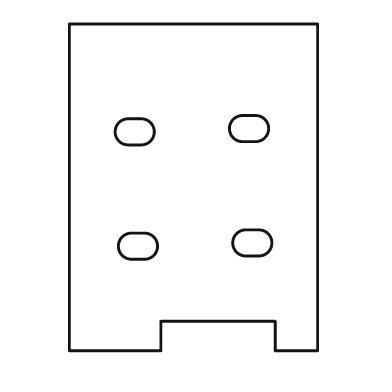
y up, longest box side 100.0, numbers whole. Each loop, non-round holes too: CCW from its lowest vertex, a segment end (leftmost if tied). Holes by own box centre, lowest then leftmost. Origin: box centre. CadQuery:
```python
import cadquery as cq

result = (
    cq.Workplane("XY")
    .moveTo(-38.0, -50.0)
    .lineTo(-10.0, -50.0)
    .lineTo(-10.0, -41.0)
    .lineTo(25.0, -41.0)
    .lineTo(25.0, -50.0)
    .lineTo(38.0, -50.0)
    .lineTo(38.0, 50.0)
    .lineTo(-38.0, 50.0)
    .close()
    .moveTo(-19.0, -22.0)
    .lineTo(-15.0, -22.0)
    .threePointArc((-11.0, -18.0), (-15.0, -14.0))
    .lineTo(-19.0, -14.0)
    .threePointArc((-23.0, -18.0), (-19.0, -22.0))
    .close()
    .moveTo(16.0, -21.0)
    .lineTo(20.0, -21.0)
    .threePointArc((24.0, -17.0), (20.0, -13.0))
    .lineTo(16.0, -13.0)
    .threePointArc((12.0, -17.0), (16.0, -21.0))
    .close()
    .moveTo(-20.0, 13.0)
    .lineTo(-16.0, 13.0)
    .threePointArc((-12.0, 17.0), (-16.0, 21.0))
    .lineTo(-20.0, 21.0)
    .threePointArc((-24.0, 17.0), (-20.0, 13.0))
    .close()
    .moveTo(15.0, 14.0)
    .lineTo(19.0, 14.0)
    .threePointArc((23.0, 18.0), (19.0, 22.0))
    .lineTo(15.0, 22.0)
    .threePointArc((11.0, 18.0), (15.0, 14.0))
    .close()
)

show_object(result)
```